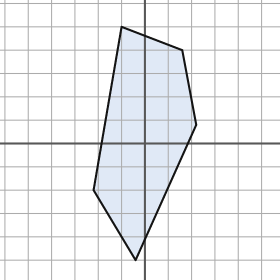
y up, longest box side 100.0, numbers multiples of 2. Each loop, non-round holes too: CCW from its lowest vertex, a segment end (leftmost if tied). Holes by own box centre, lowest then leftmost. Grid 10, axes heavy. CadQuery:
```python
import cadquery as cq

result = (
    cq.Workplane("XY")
    .moveTo(-4.0, -50.0)
    .lineTo(22.0, 8.0)
    .lineTo(16.0, 40.0)
    .lineTo(-10.0, 50.0)
    .lineTo(-22.0, -20.0)
    .close()
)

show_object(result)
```